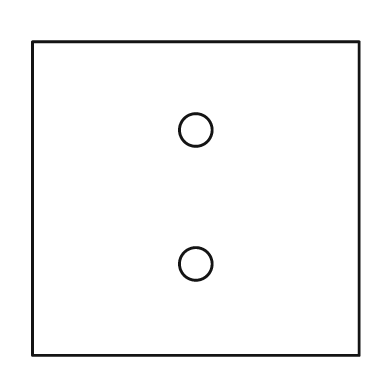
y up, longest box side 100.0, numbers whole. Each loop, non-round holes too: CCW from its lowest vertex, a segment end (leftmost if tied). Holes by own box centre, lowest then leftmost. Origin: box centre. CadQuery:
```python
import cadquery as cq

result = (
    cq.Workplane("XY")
    .moveTo(-50.0, -48.0)
    .lineTo(50.0, -48.0)
    .lineTo(50.0, 48.0)
    .lineTo(-50.0, 48.0)
    .close()
    .moveTo(0.0, -20.0)
    .circle(5.0)
    .moveTo(0.0, 21.0)
    .circle(5.0)
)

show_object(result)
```